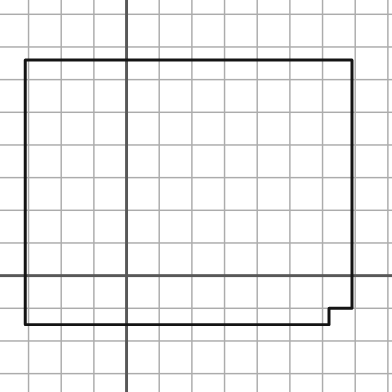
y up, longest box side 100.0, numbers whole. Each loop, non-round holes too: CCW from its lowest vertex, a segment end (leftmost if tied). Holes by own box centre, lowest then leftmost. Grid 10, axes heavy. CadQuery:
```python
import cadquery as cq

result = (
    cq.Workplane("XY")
    .moveTo(-31.0, -15.0)
    .lineTo(62.0, -15.0)
    .lineTo(62.0, -10.0)
    .lineTo(69.0, -10.0)
    .lineTo(69.0, 66.0)
    .lineTo(-31.0, 66.0)
    .close()
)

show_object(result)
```